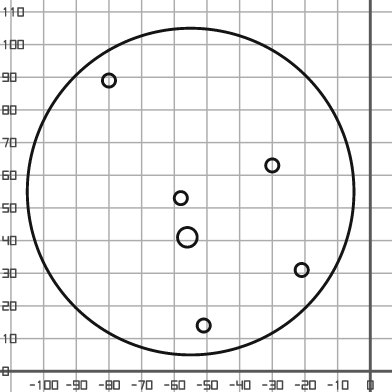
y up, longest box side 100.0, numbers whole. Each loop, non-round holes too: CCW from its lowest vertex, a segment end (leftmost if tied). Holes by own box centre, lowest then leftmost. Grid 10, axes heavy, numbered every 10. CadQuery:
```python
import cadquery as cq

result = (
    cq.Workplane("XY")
    .moveTo(-55.0, 55.0)
    .circle(50.0)
    .moveTo(-51.0, 14.0)
    .circle(2.0)
    .moveTo(-21.0, 31.0)
    .circle(2.0)
    .moveTo(-56.0, 41.0)
    .circle(3.0)
    .moveTo(-58.0, 53.0)
    .circle(2.0)
    .moveTo(-30.0, 63.0)
    .circle(2.0)
    .moveTo(-80.0, 89.0)
    .circle(2.0)
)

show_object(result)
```